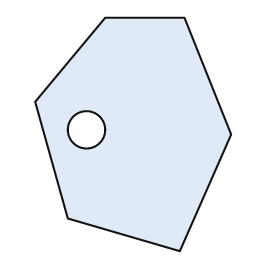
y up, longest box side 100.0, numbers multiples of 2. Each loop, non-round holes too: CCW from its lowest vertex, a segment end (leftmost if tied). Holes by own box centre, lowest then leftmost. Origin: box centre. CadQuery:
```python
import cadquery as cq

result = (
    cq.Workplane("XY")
    .moveTo(20.0, -50.0)
    .lineTo(42.0, 0.0)
    .lineTo(22.0, 50.0)
    .lineTo(-12.0, 50.0)
    .lineTo(-42.0, 14.0)
    .lineTo(-28.0, -36.0)
    .close()
    .moveTo(-20.0, 2.0)
    .circle(8.0)
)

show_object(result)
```